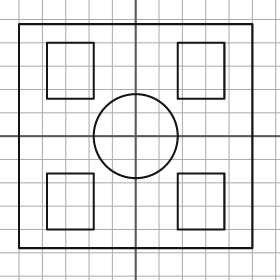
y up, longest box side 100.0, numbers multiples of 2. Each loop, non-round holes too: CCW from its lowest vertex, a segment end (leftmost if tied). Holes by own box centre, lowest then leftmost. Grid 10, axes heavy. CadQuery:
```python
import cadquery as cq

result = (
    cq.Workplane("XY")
    .moveTo(-50.0, -48.0)
    .lineTo(50.0, -48.0)
    .lineTo(50.0, 48.0)
    .lineTo(-50.0, 48.0)
    .close()
    .moveTo(-38.0, -40.0)
    .lineTo(-18.0, -40.0)
    .lineTo(-18.0, -16.0)
    .lineTo(-38.0, -16.0)
    .close()
    .moveTo(18.0, -40.0)
    .lineTo(38.0, -40.0)
    .lineTo(38.0, -16.0)
    .lineTo(18.0, -16.0)
    .close()
    .moveTo(0.0, 0.0)
    .circle(18.0)
    .moveTo(-38.0, 16.0)
    .lineTo(-18.0, 16.0)
    .lineTo(-18.0, 40.0)
    .lineTo(-38.0, 40.0)
    .close()
    .moveTo(18.0, 16.0)
    .lineTo(38.0, 16.0)
    .lineTo(38.0, 40.0)
    .lineTo(18.0, 40.0)
    .close()
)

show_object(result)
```